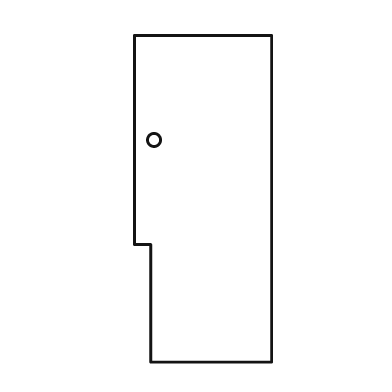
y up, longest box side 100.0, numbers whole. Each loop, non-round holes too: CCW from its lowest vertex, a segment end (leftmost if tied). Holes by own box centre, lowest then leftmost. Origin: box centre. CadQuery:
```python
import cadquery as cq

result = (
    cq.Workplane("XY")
    .moveTo(-16.0, -50.0)
    .lineTo(21.0, -50.0)
    .lineTo(21.0, 50.0)
    .lineTo(-21.0, 50.0)
    .lineTo(-21.0, -14.0)
    .lineTo(-16.0, -14.0)
    .close()
    .moveTo(-15.0, 18.0)
    .circle(2.0)
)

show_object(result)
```